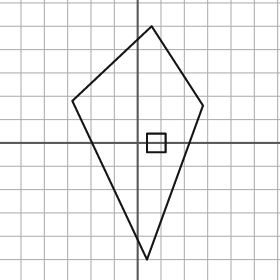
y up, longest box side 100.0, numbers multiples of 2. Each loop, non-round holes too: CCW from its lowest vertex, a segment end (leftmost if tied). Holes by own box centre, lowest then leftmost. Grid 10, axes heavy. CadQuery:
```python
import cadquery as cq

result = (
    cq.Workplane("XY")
    .moveTo(4.0, -50.0)
    .lineTo(28.0, 16.0)
    .lineTo(6.0, 50.0)
    .lineTo(-28.0, 18.0)
    .close()
    .moveTo(4.0, -4.0)
    .lineTo(12.0, -4.0)
    .lineTo(12.0, 4.0)
    .lineTo(4.0, 4.0)
    .close()
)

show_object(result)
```